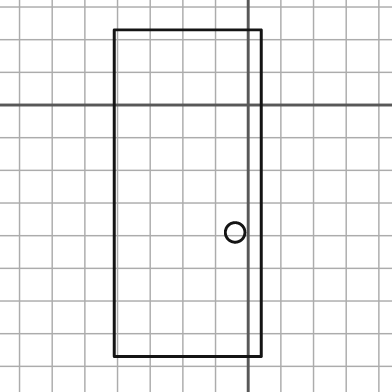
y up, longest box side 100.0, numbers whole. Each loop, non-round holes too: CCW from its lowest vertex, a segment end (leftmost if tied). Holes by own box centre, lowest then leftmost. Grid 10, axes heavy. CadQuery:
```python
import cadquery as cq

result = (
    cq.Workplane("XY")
    .moveTo(-41.0, -77.0)
    .lineTo(4.0, -77.0)
    .lineTo(4.0, 23.0)
    .lineTo(-41.0, 23.0)
    .close()
    .moveTo(-4.0, -39.0)
    .circle(3.0)
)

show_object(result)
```